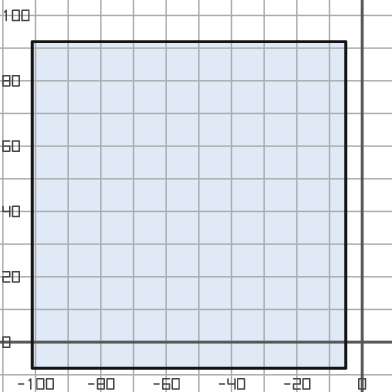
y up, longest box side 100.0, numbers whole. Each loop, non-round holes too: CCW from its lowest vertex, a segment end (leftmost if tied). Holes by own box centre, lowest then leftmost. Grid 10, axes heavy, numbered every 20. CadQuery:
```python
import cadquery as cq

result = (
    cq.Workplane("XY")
    .moveTo(-101.0, -8.0)
    .lineTo(-5.0, -8.0)
    .lineTo(-5.0, 92.0)
    .lineTo(-101.0, 92.0)
    .close()
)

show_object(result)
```